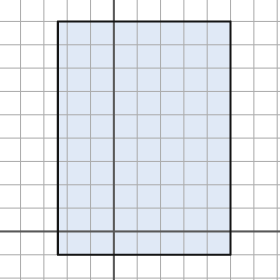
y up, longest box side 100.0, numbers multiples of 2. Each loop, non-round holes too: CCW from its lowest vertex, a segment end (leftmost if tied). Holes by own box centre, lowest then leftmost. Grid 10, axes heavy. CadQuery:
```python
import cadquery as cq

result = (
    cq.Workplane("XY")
    .moveTo(-24.0, -10.0)
    .lineTo(50.0, -10.0)
    .lineTo(50.0, 90.0)
    .lineTo(-24.0, 90.0)
    .close()
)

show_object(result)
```